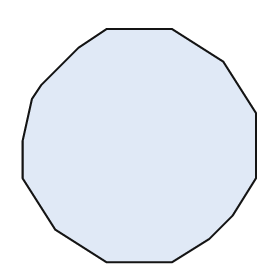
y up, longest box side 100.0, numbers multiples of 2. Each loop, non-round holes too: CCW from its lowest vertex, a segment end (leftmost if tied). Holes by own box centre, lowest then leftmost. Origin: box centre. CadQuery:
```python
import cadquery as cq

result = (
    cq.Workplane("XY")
    .moveTo(-14.0, -50.0)
    .lineTo(14.0, -50.0)
    .lineTo(30.0, -40.0)
    .lineTo(40.0, -30.0)
    .lineTo(50.0, -14.0)
    .lineTo(50.0, 14.0)
    .lineTo(36.0, 36.0)
    .lineTo(14.0, 50.0)
    .lineTo(-14.0, 50.0)
    .lineTo(-26.0, 42.0)
    .lineTo(-42.0, 26.0)
    .lineTo(-46.0, 20.0)
    .lineTo(-50.0, 2.0)
    .lineTo(-50.0, -14.0)
    .lineTo(-36.0, -36.0)
    .close()
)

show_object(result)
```